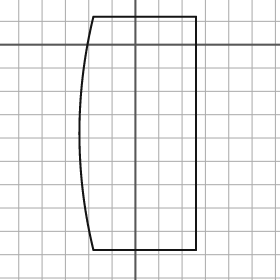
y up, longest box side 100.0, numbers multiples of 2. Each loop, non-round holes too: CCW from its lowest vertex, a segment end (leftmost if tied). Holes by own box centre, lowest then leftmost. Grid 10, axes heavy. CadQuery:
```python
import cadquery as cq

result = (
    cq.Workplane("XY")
    .moveTo(-18.0, -88.0)
    .lineTo(26.0, -88.0)
    .lineTo(26.0, 12.0)
    .lineTo(-18.0, 12.0)
    .threePointArc((-24.0, -38.0), (-18.0, -88.0))
    .close()
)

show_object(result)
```